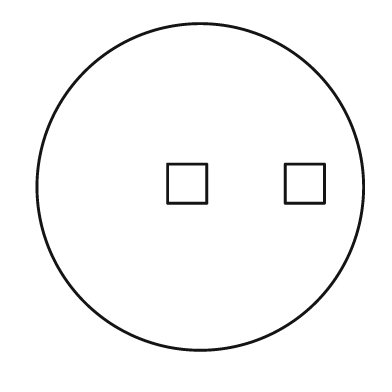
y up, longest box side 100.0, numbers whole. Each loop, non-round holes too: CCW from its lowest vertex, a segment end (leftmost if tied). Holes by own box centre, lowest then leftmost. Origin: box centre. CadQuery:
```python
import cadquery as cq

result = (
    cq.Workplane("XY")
    .moveTo(0.0, 0.0)
    .circle(50.0)
    .moveTo(-10.0, -5.0)
    .lineTo(2.0, -5.0)
    .lineTo(2.0, 7.0)
    .lineTo(-10.0, 7.0)
    .close()
    .moveTo(26.0, -5.0)
    .lineTo(38.0, -5.0)
    .lineTo(38.0, 7.0)
    .lineTo(26.0, 7.0)
    .close()
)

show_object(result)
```